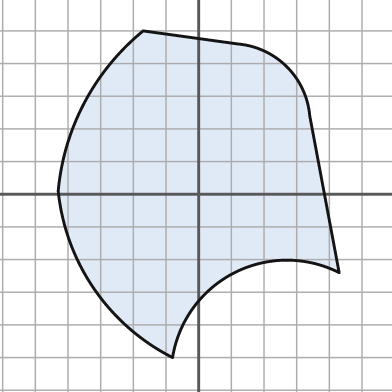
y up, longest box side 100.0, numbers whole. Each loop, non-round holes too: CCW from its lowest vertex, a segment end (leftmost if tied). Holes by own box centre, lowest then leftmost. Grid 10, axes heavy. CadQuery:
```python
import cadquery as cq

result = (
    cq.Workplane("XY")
    .moveTo(-8.0, -50.0)
    .threePointArc((11.0, -24.0), (43.0, -24.0))
    .lineTo(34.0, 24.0)
    .threePointArc((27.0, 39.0), (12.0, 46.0))
    .lineTo(-17.0, 50.0)
    .threePointArc((-35.0, 28.0), (-43.0, 1.0))
    .threePointArc((-32.0, -29.0), (-8.0, -50.0))
    .close()
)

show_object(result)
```